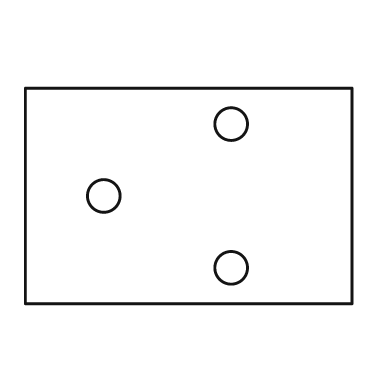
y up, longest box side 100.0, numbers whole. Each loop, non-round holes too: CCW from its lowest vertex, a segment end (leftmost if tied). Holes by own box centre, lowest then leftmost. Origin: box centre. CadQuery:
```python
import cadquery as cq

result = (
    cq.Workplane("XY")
    .moveTo(-50.0, -33.0)
    .lineTo(50.0, -33.0)
    .lineTo(50.0, 33.0)
    .lineTo(-50.0, 33.0)
    .close()
    .moveTo(13.0, -22.0)
    .circle(5.0)
    .moveTo(-26.0, 0.0)
    .circle(5.0)
    .moveTo(13.0, 22.0)
    .circle(5.0)
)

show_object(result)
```